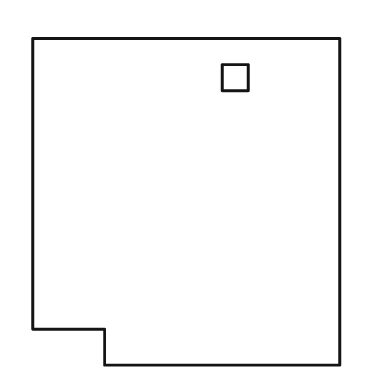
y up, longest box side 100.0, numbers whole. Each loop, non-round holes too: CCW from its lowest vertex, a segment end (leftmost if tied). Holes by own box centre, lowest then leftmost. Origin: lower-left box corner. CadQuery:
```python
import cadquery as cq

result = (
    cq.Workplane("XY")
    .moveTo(22.0, 0.0)
    .lineTo(94.0, 0.0)
    .lineTo(94.0, 100.0)
    .lineTo(0.0, 100.0)
    .lineTo(0.0, 11.0)
    .lineTo(22.0, 11.0)
    .close()
    .moveTo(58.0, 84.0)
    .lineTo(66.0, 84.0)
    .lineTo(66.0, 92.0)
    .lineTo(58.0, 92.0)
    .close()
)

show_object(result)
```